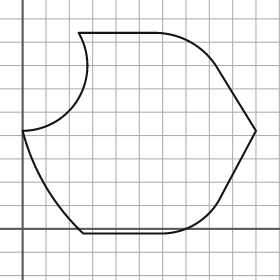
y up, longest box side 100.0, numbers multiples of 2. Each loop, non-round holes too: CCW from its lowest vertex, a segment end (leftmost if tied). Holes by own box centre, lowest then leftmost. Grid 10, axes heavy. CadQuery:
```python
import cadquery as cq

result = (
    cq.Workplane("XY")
    .moveTo(26.0, -2.0)
    .lineTo(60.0, -2.0)
    .threePointArc((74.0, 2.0), (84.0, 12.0))
    .lineTo(100.0, 42.0)
    .lineTo(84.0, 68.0)
    .threePointArc((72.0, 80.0), (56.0, 84.0))
    .lineTo(24.0, 84.0)
    .threePointArc((24.0, 56.0), (0.0, 42.0))
    .threePointArc((10.0, 18.0), (26.0, -2.0))
    .close()
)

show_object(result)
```